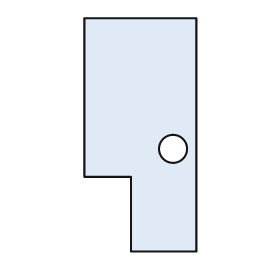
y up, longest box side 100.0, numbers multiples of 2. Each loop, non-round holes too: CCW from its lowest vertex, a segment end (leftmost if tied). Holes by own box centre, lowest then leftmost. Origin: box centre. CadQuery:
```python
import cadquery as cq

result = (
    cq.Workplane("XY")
    .moveTo(-4.0, -50.0)
    .lineTo(24.0, -50.0)
    .lineTo(24.0, 50.0)
    .lineTo(-24.0, 50.0)
    .lineTo(-24.0, -18.0)
    .lineTo(-4.0, -18.0)
    .close()
    .moveTo(14.0, -6.0)
    .circle(6.0)
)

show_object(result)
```